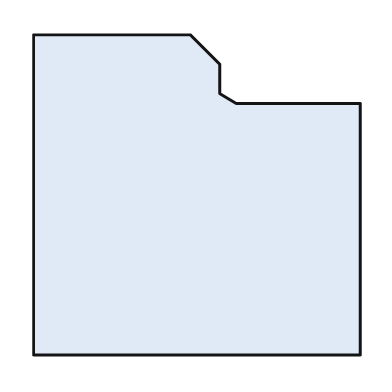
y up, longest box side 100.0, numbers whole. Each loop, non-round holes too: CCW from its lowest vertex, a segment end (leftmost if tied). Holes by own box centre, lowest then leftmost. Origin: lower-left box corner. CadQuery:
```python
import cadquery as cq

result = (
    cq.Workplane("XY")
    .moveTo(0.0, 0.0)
    .lineTo(100.0, 0.0)
    .lineTo(100.0, 77.0)
    .lineTo(62.0, 77.0)
    .lineTo(57.0, 80.0)
    .lineTo(57.0, 89.0)
    .lineTo(48.0, 98.0)
    .lineTo(0.0, 98.0)
    .close()
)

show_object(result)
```